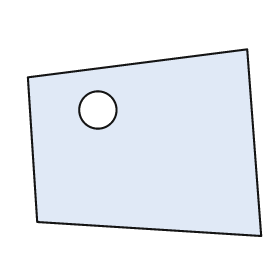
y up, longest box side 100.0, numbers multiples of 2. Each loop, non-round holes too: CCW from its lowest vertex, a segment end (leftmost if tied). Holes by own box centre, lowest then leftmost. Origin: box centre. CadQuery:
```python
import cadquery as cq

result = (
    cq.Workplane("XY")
    .moveTo(50.0, -40.0)
    .lineTo(44.0, 40.0)
    .lineTo(-50.0, 28.0)
    .lineTo(-46.0, -34.0)
    .close()
    .moveTo(-20.0, 14.0)
    .circle(8.0)
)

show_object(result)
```